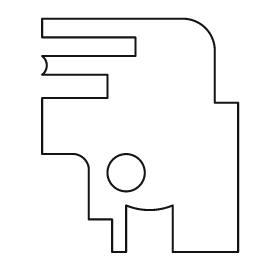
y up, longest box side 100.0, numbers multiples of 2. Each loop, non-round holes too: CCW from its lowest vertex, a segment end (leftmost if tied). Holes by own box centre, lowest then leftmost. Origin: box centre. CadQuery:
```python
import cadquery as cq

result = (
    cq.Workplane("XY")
    .moveTo(-12.0, -50.0)
    .lineTo(-6.0, -50.0)
    .lineTo(-6.0, -30.0)
    .threePointArc((4.0, -32.0), (14.0, -30.0))
    .lineTo(14.0, -50.0)
    .lineTo(42.0, -50.0)
    .lineTo(42.0, 14.0)
    .lineTo(32.0, 14.0)
    .lineTo(32.0, 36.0)
    .threePointArc((28.0, 46.0), (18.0, 50.0))
    .lineTo(-42.0, 50.0)
    .lineTo(-42.0, 42.0)
    .lineTo(-2.0, 42.0)
    .lineTo(-2.0, 34.0)
    .lineTo(-42.0, 34.0)
    .threePointArc((-40.0, 30.0), (-42.0, 26.0))
    .lineTo(-14.0, 26.0)
    .lineTo(-14.0, 16.0)
    .lineTo(-42.0, 16.0)
    .lineTo(-42.0, -8.0)
    .lineTo(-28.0, -8.0)
    .threePointArc((-24.0, -10.0), (-22.0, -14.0))
    .lineTo(-22.0, -36.0)
    .lineTo(-12.0, -36.0)
    .close()
    .moveTo(-6.0, -16.0)
    .circle(8.0)
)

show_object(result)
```